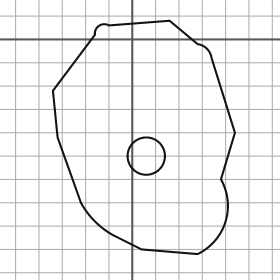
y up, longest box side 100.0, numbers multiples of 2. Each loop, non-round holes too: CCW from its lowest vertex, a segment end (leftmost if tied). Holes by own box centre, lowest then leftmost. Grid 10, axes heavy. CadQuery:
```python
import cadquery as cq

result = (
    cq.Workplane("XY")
    .moveTo(28.0, -92.0)
    .threePointArc((40.0, -78.0), (38.0, -60.0))
    .lineTo(44.0, -40.0)
    .lineTo(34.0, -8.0)
    .threePointArc((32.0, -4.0), (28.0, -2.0))
    .lineTo(16.0, 8.0)
    .lineTo(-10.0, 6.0)
    .threePointArc((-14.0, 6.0), (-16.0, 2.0))
    .lineTo(-34.0, -22.0)
    .lineTo(-32.0, -42.0)
    .lineTo(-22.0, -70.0)
    .threePointArc((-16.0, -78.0), (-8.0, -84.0))
    .lineTo(4.0, -90.0)
    .close()
    .moveTo(6.0, -50.0)
    .circle(8.0)
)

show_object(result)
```